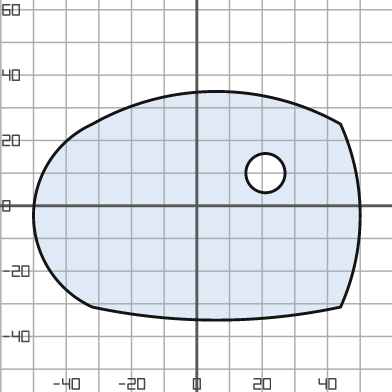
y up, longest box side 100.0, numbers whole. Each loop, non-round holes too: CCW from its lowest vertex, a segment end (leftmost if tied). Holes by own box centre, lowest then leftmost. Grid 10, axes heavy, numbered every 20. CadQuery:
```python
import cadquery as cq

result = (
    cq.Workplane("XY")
    .moveTo(-32.0, -31.0)
    .threePointArc((6.0, -35.0), (44.0, -31.0))
    .threePointArc((50.0, -3.0), (44.0, 25.0))
    .threePointArc((6.0, 35.0), (-32.0, 25.0))
    .threePointArc((-50.0, -3.0), (-32.0, -31.0))
    .close()
    .moveTo(21.0, 10.0)
    .circle(6.0)
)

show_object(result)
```